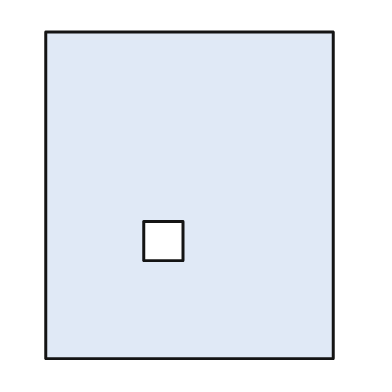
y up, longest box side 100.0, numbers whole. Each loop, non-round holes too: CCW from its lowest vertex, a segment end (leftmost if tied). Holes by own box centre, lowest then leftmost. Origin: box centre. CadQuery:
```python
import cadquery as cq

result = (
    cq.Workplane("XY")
    .moveTo(-44.0, -50.0)
    .lineTo(44.0, -50.0)
    .lineTo(44.0, 50.0)
    .lineTo(-44.0, 50.0)
    .close()
    .moveTo(-14.0, -20.0)
    .lineTo(-2.0, -20.0)
    .lineTo(-2.0, -8.0)
    .lineTo(-14.0, -8.0)
    .close()
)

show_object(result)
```